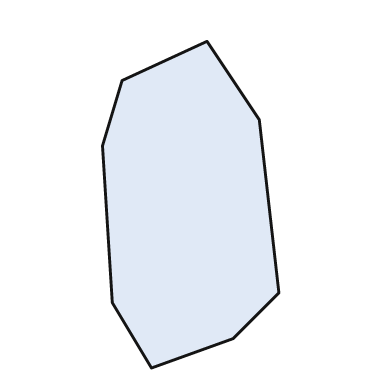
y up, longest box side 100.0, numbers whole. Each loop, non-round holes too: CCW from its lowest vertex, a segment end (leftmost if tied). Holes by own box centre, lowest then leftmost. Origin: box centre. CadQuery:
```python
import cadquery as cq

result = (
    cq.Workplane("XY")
    .moveTo(-12.0, -50.0)
    .lineTo(13.0, -41.0)
    .lineTo(27.0, -27.0)
    .lineTo(21.0, 26.0)
    .lineTo(5.0, 50.0)
    .lineTo(-21.0, 38.0)
    .lineTo(-27.0, 18.0)
    .lineTo(-24.0, -30.0)
    .close()
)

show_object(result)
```